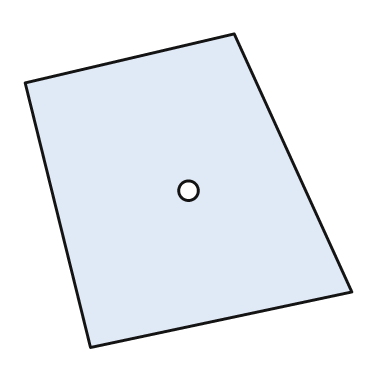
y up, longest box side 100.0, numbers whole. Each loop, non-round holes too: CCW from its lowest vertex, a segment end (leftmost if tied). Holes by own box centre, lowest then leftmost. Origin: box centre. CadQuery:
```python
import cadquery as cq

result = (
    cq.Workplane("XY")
    .moveTo(-30.0, -48.0)
    .lineTo(50.0, -31.0)
    .lineTo(14.0, 48.0)
    .lineTo(-50.0, 33.0)
    .close()
    .moveTo(0.0, 0.0)
    .circle(3.0)
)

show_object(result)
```